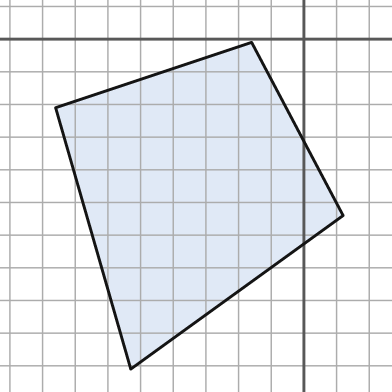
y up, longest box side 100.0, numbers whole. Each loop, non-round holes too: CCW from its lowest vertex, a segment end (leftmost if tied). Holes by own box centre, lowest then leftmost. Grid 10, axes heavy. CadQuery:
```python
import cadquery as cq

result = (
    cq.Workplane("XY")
    .moveTo(-53.0, -101.0)
    .lineTo(12.0, -54.0)
    .lineTo(-16.0, -1.0)
    .lineTo(-76.0, -21.0)
    .close()
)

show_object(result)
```